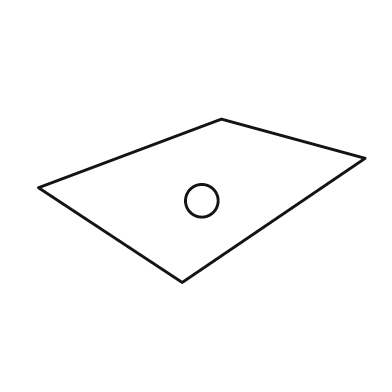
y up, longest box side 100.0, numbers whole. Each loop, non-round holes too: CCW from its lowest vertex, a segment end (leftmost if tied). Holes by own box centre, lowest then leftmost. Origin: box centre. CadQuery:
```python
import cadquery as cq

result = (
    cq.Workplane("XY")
    .moveTo(-6.0, -25.0)
    .lineTo(50.0, 13.0)
    .lineTo(6.0, 25.0)
    .lineTo(-50.0, 4.0)
    .close()
    .moveTo(0.0, 0.0)
    .circle(5.0)
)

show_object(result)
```